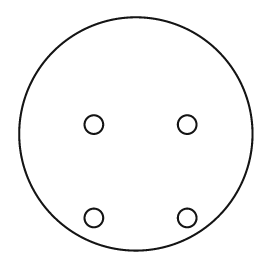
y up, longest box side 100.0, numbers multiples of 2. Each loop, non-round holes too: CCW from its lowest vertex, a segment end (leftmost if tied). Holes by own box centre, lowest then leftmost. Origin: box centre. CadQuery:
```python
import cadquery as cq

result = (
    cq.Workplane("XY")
    .moveTo(0.0, 0.0)
    .circle(50.0)
    .moveTo(-18.0, -36.0)
    .circle(4.0)
    .moveTo(22.0, -36.0)
    .circle(4.0)
    .moveTo(-18.0, 4.0)
    .circle(4.0)
    .moveTo(22.0, 4.0)
    .circle(4.0)
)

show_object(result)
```